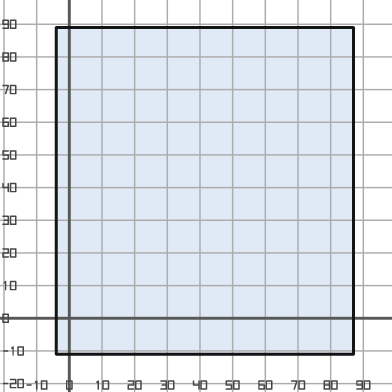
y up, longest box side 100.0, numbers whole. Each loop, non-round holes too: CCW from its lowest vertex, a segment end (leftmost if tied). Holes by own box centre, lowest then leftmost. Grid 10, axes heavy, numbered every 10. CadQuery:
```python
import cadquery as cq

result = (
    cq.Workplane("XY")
    .moveTo(-4.0, -11.0)
    .lineTo(87.0, -11.0)
    .lineTo(87.0, 89.0)
    .lineTo(-4.0, 89.0)
    .close()
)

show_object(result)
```